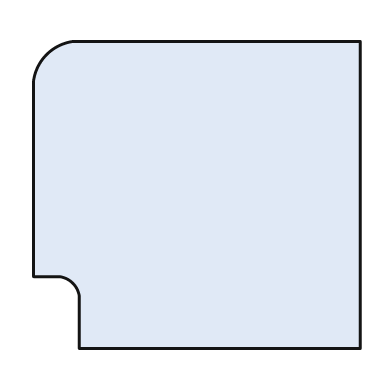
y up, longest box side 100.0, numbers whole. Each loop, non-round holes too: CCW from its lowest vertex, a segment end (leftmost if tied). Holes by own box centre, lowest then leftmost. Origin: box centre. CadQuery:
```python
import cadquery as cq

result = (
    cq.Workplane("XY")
    .moveTo(-36.0, -47.0)
    .lineTo(50.0, -47.0)
    .lineTo(50.0, 47.0)
    .lineTo(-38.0, 47.0)
    .threePointArc((-46.0, 43.0), (-50.0, 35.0))
    .lineTo(-50.0, -25.0)
    .lineTo(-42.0, -25.0)
    .threePointArc((-38.0, -27.0), (-36.0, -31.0))
    .close()
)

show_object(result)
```